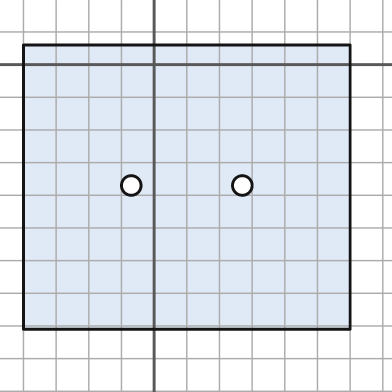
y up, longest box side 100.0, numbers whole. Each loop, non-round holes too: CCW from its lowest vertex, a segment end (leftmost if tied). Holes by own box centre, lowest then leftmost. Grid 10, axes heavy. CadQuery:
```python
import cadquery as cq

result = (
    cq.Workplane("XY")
    .moveTo(-40.0, -81.0)
    .lineTo(60.0, -81.0)
    .lineTo(60.0, 6.0)
    .lineTo(-40.0, 6.0)
    .close()
    .moveTo(-7.0, -37.0)
    .circle(3.0)
    .moveTo(27.0, -37.0)
    .circle(3.0)
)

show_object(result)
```